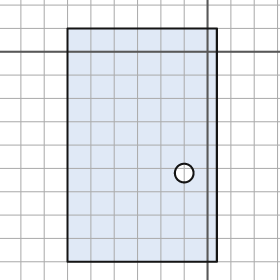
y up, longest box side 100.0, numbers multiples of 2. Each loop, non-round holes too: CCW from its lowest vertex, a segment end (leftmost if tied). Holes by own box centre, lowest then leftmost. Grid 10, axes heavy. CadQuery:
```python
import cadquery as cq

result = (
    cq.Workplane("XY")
    .moveTo(-60.0, -90.0)
    .lineTo(4.0, -90.0)
    .lineTo(4.0, 10.0)
    .lineTo(-60.0, 10.0)
    .close()
    .moveTo(-10.0, -52.0)
    .circle(4.0)
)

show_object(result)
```